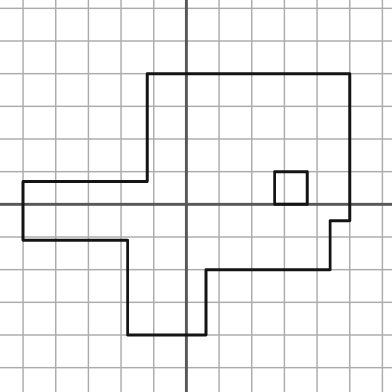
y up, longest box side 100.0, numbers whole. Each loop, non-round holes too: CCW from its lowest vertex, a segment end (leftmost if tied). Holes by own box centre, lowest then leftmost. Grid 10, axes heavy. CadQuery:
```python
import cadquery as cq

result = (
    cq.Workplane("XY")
    .moveTo(-18.0, -40.0)
    .lineTo(6.0, -40.0)
    .lineTo(6.0, -20.0)
    .lineTo(44.0, -20.0)
    .lineTo(44.0, -5.0)
    .lineTo(50.0, -5.0)
    .lineTo(50.0, 40.0)
    .lineTo(-12.0, 40.0)
    .lineTo(-12.0, 7.0)
    .lineTo(-50.0, 7.0)
    .lineTo(-50.0, -11.0)
    .lineTo(-18.0, -11.0)
    .close()
    .moveTo(27.0, 0.0)
    .lineTo(37.0, 0.0)
    .lineTo(37.0, 10.0)
    .lineTo(27.0, 10.0)
    .close()
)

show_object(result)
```